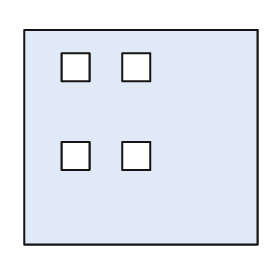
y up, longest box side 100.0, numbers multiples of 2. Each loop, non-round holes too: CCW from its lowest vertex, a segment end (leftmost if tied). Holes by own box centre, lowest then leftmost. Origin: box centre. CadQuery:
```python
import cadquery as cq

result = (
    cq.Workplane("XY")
    .moveTo(-50.0, -46.0)
    .lineTo(50.0, -46.0)
    .lineTo(50.0, 46.0)
    .lineTo(-50.0, 46.0)
    .close()
    .moveTo(-34.0, -14.0)
    .lineTo(-22.0, -14.0)
    .lineTo(-22.0, -2.0)
    .lineTo(-34.0, -2.0)
    .close()
    .moveTo(-8.0, -14.0)
    .lineTo(4.0, -14.0)
    .lineTo(4.0, -2.0)
    .lineTo(-8.0, -2.0)
    .close()
    .moveTo(-34.0, 24.0)
    .lineTo(-22.0, 24.0)
    .lineTo(-22.0, 36.0)
    .lineTo(-34.0, 36.0)
    .close()
    .moveTo(-8.0, 24.0)
    .lineTo(4.0, 24.0)
    .lineTo(4.0, 36.0)
    .lineTo(-8.0, 36.0)
    .close()
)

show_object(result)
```